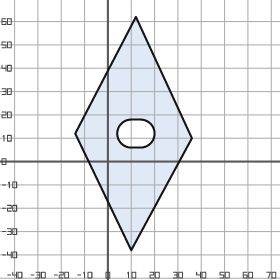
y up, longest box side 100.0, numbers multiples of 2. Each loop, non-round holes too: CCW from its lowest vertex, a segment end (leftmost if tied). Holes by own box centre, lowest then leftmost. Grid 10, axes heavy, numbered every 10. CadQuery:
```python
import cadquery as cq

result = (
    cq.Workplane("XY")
    .moveTo(10.0, -38.0)
    .lineTo(36.0, 10.0)
    .lineTo(12.0, 62.0)
    .lineTo(-14.0, 12.0)
    .close()
    .moveTo(10.0, 6.0)
    .lineTo(14.0, 6.0)
    .threePointArc((20.0, 12.0), (14.0, 18.0))
    .lineTo(10.0, 18.0)
    .threePointArc((4.0, 12.0), (10.0, 6.0))
    .close()
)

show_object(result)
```